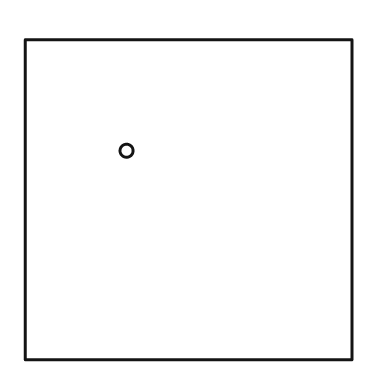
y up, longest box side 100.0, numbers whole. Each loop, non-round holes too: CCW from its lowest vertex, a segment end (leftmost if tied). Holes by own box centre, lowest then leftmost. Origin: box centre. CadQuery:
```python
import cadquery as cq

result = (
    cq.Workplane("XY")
    .moveTo(-50.0, -49.0)
    .lineTo(50.0, -49.0)
    .lineTo(50.0, 49.0)
    .lineTo(-50.0, 49.0)
    .close()
    .moveTo(-19.0, 15.0)
    .circle(2.0)
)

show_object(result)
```